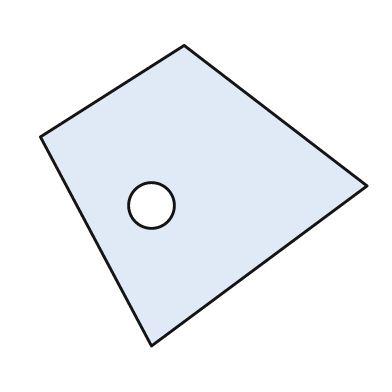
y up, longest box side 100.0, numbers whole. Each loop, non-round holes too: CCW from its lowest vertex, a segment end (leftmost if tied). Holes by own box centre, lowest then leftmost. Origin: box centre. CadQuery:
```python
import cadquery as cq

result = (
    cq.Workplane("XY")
    .moveTo(-16.0, -46.0)
    .lineTo(50.0, 3.0)
    .lineTo(-6.0, 46.0)
    .lineTo(-50.0, 18.0)
    .close()
    .moveTo(-16.0, -3.0)
    .circle(7.0)
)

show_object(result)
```